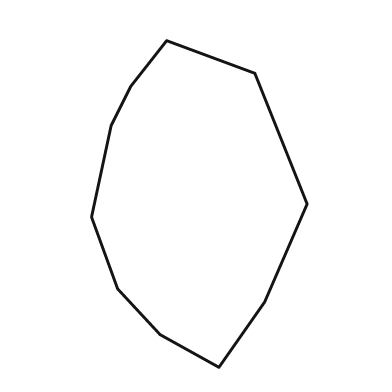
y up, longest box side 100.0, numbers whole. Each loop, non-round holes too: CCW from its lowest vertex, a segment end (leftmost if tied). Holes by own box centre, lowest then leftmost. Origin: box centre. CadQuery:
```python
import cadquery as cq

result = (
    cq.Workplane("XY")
    .moveTo(6.0, -50.0)
    .lineTo(20.0, -30.0)
    .lineTo(33.0, 0.0)
    .lineTo(17.0, 40.0)
    .lineTo(-10.0, 50.0)
    .lineTo(-21.0, 36.0)
    .lineTo(-27.0, 24.0)
    .lineTo(-33.0, -4.0)
    .lineTo(-25.0, -26.0)
    .lineTo(-12.0, -40.0)
    .close()
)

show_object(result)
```